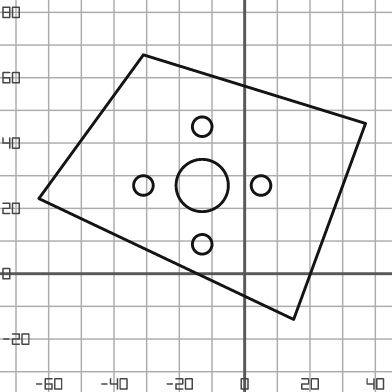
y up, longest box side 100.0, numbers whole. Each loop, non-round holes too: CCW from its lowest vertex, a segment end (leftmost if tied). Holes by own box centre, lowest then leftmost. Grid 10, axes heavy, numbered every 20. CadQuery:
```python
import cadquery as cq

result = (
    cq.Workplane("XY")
    .moveTo(15.0, -14.0)
    .lineTo(37.0, 46.0)
    .lineTo(-31.0, 67.0)
    .lineTo(-63.0, 23.0)
    .close()
    .moveTo(-13.0, 9.0)
    .circle(3.0)
    .moveTo(-31.0, 27.0)
    .circle(3.0)
    .moveTo(-13.0, 27.0)
    .circle(8.0)
    .moveTo(5.0, 27.0)
    .circle(3.0)
    .moveTo(-13.0, 45.0)
    .circle(3.0)
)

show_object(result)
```